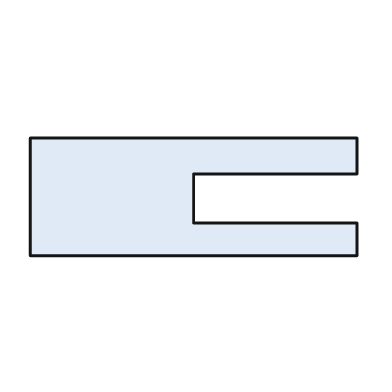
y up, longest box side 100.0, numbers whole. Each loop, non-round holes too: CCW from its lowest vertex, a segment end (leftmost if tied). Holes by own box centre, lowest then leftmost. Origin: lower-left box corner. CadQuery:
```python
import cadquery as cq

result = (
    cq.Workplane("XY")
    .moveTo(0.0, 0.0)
    .lineTo(100.0, 0.0)
    .lineTo(100.0, 10.0)
    .lineTo(50.0, 10.0)
    .lineTo(50.0, 25.0)
    .lineTo(100.0, 25.0)
    .lineTo(100.0, 36.0)
    .lineTo(0.0, 36.0)
    .close()
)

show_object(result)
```